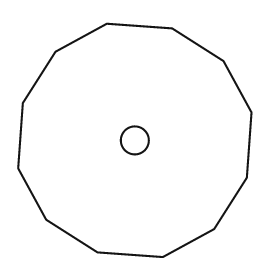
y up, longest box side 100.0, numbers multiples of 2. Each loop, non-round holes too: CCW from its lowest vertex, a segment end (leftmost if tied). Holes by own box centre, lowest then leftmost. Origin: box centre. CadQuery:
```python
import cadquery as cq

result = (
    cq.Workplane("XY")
    .moveTo(12.0, -50.0)
    .lineTo(34.0, -38.0)
    .lineTo(48.0, -16.0)
    .lineTo(50.0, 12.0)
    .lineTo(38.0, 34.0)
    .lineTo(16.0, 48.0)
    .lineTo(-12.0, 50.0)
    .lineTo(-34.0, 38.0)
    .lineTo(-48.0, 16.0)
    .lineTo(-50.0, -12.0)
    .lineTo(-38.0, -34.0)
    .lineTo(-16.0, -48.0)
    .close()
    .moveTo(0.0, 0.0)
    .circle(6.0)
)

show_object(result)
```